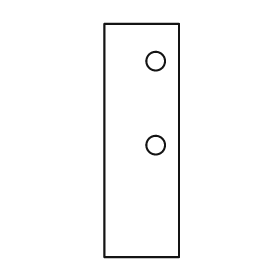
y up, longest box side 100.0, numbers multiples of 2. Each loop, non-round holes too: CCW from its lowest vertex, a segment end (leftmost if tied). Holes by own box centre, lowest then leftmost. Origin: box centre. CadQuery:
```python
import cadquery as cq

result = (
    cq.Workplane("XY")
    .moveTo(-16.0, -50.0)
    .lineTo(16.0, -50.0)
    .lineTo(16.0, 50.0)
    .lineTo(-16.0, 50.0)
    .close()
    .moveTo(6.0, -2.0)
    .circle(4.0)
    .moveTo(6.0, 34.0)
    .circle(4.0)
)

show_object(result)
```